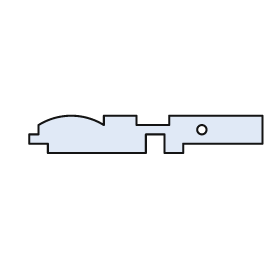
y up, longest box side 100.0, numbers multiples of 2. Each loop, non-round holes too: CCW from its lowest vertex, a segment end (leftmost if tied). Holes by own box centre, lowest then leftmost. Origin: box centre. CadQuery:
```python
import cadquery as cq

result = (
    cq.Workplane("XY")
    .moveTo(-42.0, -8.0)
    .lineTo(0.0, -8.0)
    .lineTo(0.0, 0.0)
    .lineTo(8.0, 0.0)
    .lineTo(8.0, -8.0)
    .lineTo(16.0, -8.0)
    .lineTo(16.0, -4.0)
    .lineTo(50.0, -4.0)
    .lineTo(50.0, 8.0)
    .lineTo(10.0, 8.0)
    .lineTo(10.0, 4.0)
    .lineTo(-4.0, 4.0)
    .lineTo(-4.0, 8.0)
    .lineTo(-18.0, 8.0)
    .lineTo(-18.0, 4.0)
    .threePointArc((-32.0, 8.0), (-46.0, 4.0))
    .lineTo(-46.0, 0.0)
    .lineTo(-50.0, 0.0)
    .lineTo(-50.0, -4.0)
    .lineTo(-42.0, -4.0)
    .close()
    .moveTo(24.0, 2.0)
    .circle(2.0)
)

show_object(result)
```